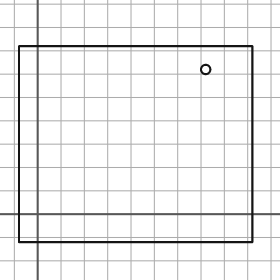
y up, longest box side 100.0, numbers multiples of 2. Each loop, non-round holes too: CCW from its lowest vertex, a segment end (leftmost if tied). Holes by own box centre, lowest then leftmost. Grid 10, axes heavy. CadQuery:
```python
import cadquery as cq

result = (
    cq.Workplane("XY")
    .moveTo(-8.0, -12.0)
    .lineTo(92.0, -12.0)
    .lineTo(92.0, 72.0)
    .lineTo(-8.0, 72.0)
    .close()
    .moveTo(72.0, 62.0)
    .circle(2.0)
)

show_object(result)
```